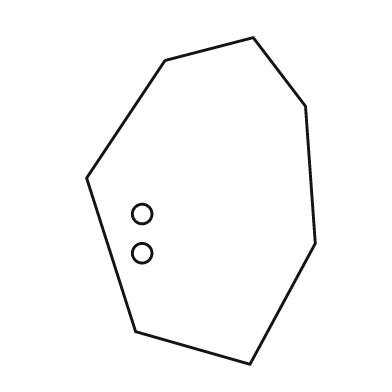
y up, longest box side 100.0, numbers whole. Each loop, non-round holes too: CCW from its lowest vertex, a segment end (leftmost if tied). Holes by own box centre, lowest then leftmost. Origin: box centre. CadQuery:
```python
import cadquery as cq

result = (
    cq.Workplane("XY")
    .moveTo(15.0, -50.0)
    .lineTo(35.0, -13.0)
    .lineTo(32.0, 29.0)
    .lineTo(16.0, 50.0)
    .lineTo(-11.0, 43.0)
    .lineTo(-35.0, 7.0)
    .lineTo(-20.0, -40.0)
    .close()
    .moveTo(-18.0, -16.0)
    .circle(3.0)
    .moveTo(-18.0, -4.0)
    .circle(3.0)
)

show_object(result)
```